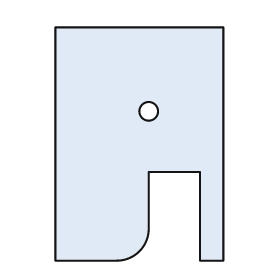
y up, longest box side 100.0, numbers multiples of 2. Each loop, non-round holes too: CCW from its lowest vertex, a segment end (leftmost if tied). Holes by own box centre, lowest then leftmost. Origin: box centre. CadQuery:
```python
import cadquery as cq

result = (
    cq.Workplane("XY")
    .moveTo(-36.0, -50.0)
    .lineTo(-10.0, -50.0)
    .threePointArc((0.0, -46.0), (4.0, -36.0))
    .lineTo(4.0, -12.0)
    .lineTo(26.0, -12.0)
    .lineTo(26.0, -50.0)
    .lineTo(36.0, -50.0)
    .lineTo(36.0, 50.0)
    .lineTo(-36.0, 50.0)
    .close()
    .moveTo(4.0, 14.0)
    .circle(4.0)
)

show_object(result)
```